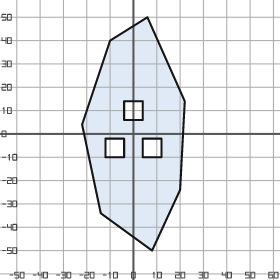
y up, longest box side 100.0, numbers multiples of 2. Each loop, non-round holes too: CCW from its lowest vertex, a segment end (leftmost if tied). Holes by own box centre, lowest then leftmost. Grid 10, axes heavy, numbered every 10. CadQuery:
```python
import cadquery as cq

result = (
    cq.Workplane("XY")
    .moveTo(8.0, -50.0)
    .lineTo(20.0, -24.0)
    .lineTo(22.0, 14.0)
    .lineTo(6.0, 50.0)
    .lineTo(-10.0, 40.0)
    .lineTo(-22.0, 4.0)
    .lineTo(-14.0, -34.0)
    .close()
    .moveTo(-12.0, -10.0)
    .lineTo(-4.0, -10.0)
    .lineTo(-4.0, -2.0)
    .lineTo(-12.0, -2.0)
    .close()
    .moveTo(4.0, -10.0)
    .lineTo(12.0, -10.0)
    .lineTo(12.0, -2.0)
    .lineTo(4.0, -2.0)
    .close()
    .moveTo(-4.0, 6.0)
    .lineTo(4.0, 6.0)
    .lineTo(4.0, 14.0)
    .lineTo(-4.0, 14.0)
    .close()
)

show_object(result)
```